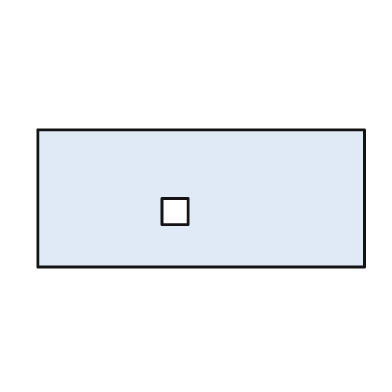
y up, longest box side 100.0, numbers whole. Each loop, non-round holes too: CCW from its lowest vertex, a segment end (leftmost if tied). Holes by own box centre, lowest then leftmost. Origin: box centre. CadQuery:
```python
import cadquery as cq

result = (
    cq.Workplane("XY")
    .moveTo(-50.0, -21.0)
    .lineTo(50.0, -21.0)
    .lineTo(50.0, 21.0)
    .lineTo(-50.0, 21.0)
    .close()
    .moveTo(-12.0, -8.0)
    .lineTo(-4.0, -8.0)
    .lineTo(-4.0, 0.0)
    .lineTo(-12.0, 0.0)
    .close()
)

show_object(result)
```